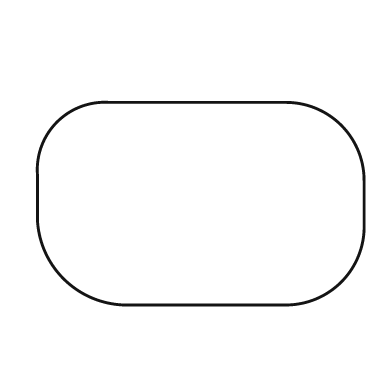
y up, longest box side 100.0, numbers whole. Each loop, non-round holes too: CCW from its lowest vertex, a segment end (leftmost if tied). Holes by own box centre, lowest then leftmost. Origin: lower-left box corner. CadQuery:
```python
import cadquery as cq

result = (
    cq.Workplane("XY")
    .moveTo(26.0, 0.0)
    .lineTo(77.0, 0.0)
    .threePointArc((93.0, 7.0), (100.0, 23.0))
    .lineTo(100.0, 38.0)
    .threePointArc((93.0, 55.0), (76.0, 62.0))
    .lineTo(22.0, 62.0)
    .threePointArc((6.0, 56.0), (0.0, 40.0))
    .lineTo(0.0, 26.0)
    .threePointArc((8.0, 8.0), (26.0, 0.0))
    .close()
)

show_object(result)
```